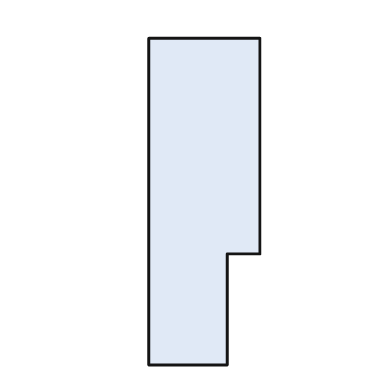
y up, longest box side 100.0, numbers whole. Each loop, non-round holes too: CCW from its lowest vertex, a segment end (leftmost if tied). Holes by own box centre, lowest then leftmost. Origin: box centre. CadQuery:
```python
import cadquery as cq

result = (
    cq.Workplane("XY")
    .moveTo(-17.0, -50.0)
    .lineTo(7.0, -50.0)
    .lineTo(7.0, -16.0)
    .lineTo(17.0, -16.0)
    .lineTo(17.0, 50.0)
    .lineTo(-17.0, 50.0)
    .close()
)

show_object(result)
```